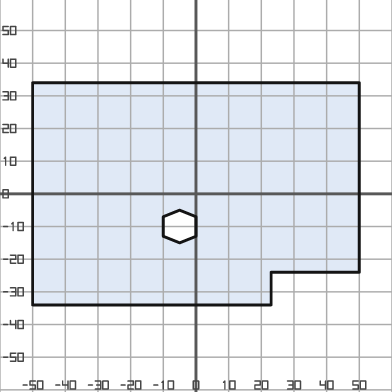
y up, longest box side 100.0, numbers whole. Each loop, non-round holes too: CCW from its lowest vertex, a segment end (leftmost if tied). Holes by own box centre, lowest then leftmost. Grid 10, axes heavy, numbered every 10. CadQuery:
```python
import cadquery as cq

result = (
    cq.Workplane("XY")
    .moveTo(-50.0, -34.0)
    .lineTo(23.0, -34.0)
    .lineTo(23.0, -24.0)
    .lineTo(50.0, -24.0)
    .lineTo(50.0, 34.0)
    .lineTo(-50.0, 34.0)
    .close()
    .moveTo(-5.0, -15.0)
    .lineTo(0.0, -13.0)
    .lineTo(0.0, -7.0)
    .lineTo(-5.0, -5.0)
    .lineTo(-10.0, -7.0)
    .lineTo(-10.0, -13.0)
    .close()
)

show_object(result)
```